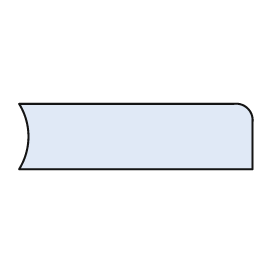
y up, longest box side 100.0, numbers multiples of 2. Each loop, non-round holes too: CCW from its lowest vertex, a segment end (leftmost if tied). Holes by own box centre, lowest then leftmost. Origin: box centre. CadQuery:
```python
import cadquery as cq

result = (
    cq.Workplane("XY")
    .moveTo(-50.0, -14.0)
    .lineTo(50.0, -14.0)
    .lineTo(50.0, 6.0)
    .threePointArc((48.0, 12.0), (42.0, 14.0))
    .lineTo(-50.0, 14.0)
    .threePointArc((-46.0, 0.0), (-50.0, -14.0))
    .close()
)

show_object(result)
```